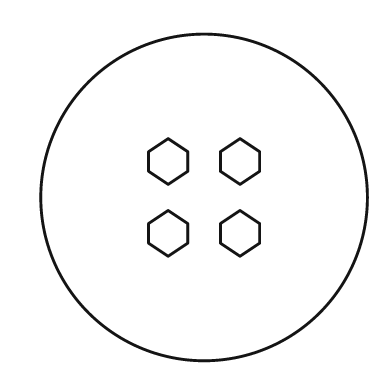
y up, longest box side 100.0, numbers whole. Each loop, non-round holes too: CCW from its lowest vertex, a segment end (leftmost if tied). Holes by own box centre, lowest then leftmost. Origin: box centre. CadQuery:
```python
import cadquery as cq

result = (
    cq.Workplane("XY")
    .moveTo(0.0, 0.0)
    .circle(50.0)
    .moveTo(-11.0, -18.0)
    .lineTo(-5.0, -14.0)
    .lineTo(-5.0, -8.0)
    .lineTo(-11.0, -4.0)
    .lineTo(-17.0, -8.0)
    .lineTo(-17.0, -14.0)
    .close()
    .moveTo(11.0, -18.0)
    .lineTo(17.0, -14.0)
    .lineTo(17.0, -8.0)
    .lineTo(11.0, -4.0)
    .lineTo(5.0, -8.0)
    .lineTo(5.0, -14.0)
    .close()
    .moveTo(-11.0, 4.0)
    .lineTo(-5.0, 8.0)
    .lineTo(-5.0, 14.0)
    .lineTo(-11.0, 18.0)
    .lineTo(-17.0, 14.0)
    .lineTo(-17.0, 8.0)
    .close()
    .moveTo(11.0, 4.0)
    .lineTo(17.0, 8.0)
    .lineTo(17.0, 14.0)
    .lineTo(11.0, 18.0)
    .lineTo(5.0, 14.0)
    .lineTo(5.0, 8.0)
    .close()
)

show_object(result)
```